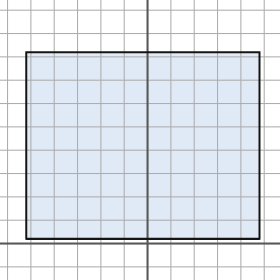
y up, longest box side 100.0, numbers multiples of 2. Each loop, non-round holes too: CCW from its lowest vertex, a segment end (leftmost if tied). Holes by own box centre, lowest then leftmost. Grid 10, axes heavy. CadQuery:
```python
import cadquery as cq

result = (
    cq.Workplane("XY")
    .moveTo(-52.0, 2.0)
    .lineTo(48.0, 2.0)
    .lineTo(48.0, 82.0)
    .lineTo(-52.0, 82.0)
    .close()
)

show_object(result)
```